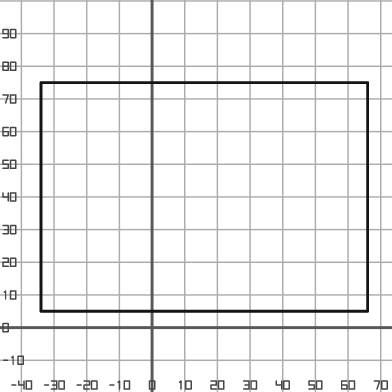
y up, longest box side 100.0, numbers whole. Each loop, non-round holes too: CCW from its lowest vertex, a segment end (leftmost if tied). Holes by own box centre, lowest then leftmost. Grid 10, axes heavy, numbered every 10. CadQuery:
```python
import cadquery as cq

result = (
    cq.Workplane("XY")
    .moveTo(-34.0, 5.0)
    .lineTo(66.0, 5.0)
    .lineTo(66.0, 75.0)
    .lineTo(-34.0, 75.0)
    .close()
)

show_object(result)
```